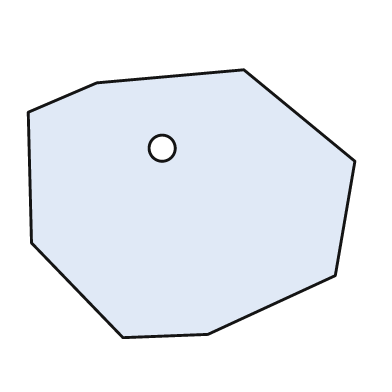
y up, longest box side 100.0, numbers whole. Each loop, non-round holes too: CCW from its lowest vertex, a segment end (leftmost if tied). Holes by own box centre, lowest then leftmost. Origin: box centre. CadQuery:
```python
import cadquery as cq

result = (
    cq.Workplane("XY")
    .moveTo(-21.0, -41.0)
    .lineTo(5.0, -40.0)
    .lineTo(44.0, -22.0)
    .lineTo(50.0, 13.0)
    .lineTo(16.0, 41.0)
    .lineTo(-29.0, 37.0)
    .lineTo(-50.0, 28.0)
    .lineTo(-49.0, -12.0)
    .close()
    .moveTo(-9.0, 17.0)
    .circle(4.0)
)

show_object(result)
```